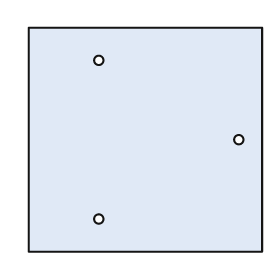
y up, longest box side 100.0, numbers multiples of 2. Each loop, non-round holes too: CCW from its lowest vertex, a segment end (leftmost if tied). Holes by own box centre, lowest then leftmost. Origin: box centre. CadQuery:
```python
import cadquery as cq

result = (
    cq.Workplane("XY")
    .moveTo(-50.0, -48.0)
    .lineTo(50.0, -48.0)
    .lineTo(50.0, 48.0)
    .lineTo(-50.0, 48.0)
    .close()
    .moveTo(-20.0, -34.0)
    .circle(2.0)
    .moveTo(40.0, 0.0)
    .circle(2.0)
    .moveTo(-20.0, 34.0)
    .circle(2.0)
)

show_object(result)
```